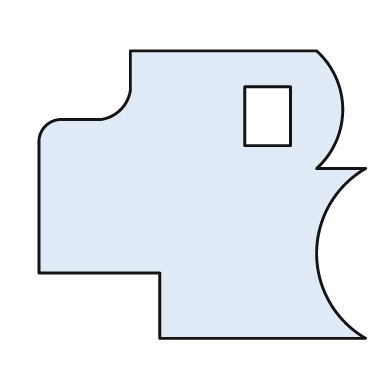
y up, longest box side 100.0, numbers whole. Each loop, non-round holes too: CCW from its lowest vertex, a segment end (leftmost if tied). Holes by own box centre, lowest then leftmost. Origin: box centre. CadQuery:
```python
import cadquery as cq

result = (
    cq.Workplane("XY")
    .moveTo(-13.0, -44.0)
    .lineTo(50.0, -44.0)
    .threePointArc((35.0, -18.0), (50.0, 8.0))
    .lineTo(35.0, 8.0)
    .threePointArc((43.0, 26.0), (35.0, 44.0))
    .lineTo(-22.0, 44.0)
    .lineTo(-22.0, 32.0)
    .threePointArc((-25.0, 26.0), (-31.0, 23.0))
    .lineTo(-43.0, 23.0)
    .threePointArc((-48.0, 21.0), (-50.0, 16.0))
    .lineTo(-50.0, -24.0)
    .lineTo(-13.0, -24.0)
    .close()
    .moveTo(13.0, 15.0)
    .lineTo(27.0, 15.0)
    .lineTo(27.0, 33.0)
    .lineTo(13.0, 33.0)
    .close()
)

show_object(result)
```